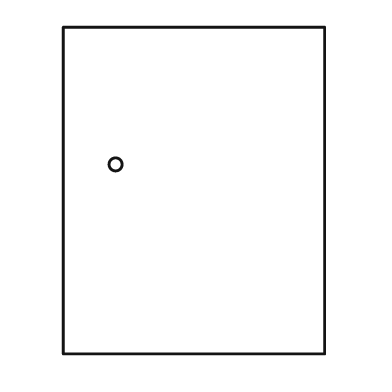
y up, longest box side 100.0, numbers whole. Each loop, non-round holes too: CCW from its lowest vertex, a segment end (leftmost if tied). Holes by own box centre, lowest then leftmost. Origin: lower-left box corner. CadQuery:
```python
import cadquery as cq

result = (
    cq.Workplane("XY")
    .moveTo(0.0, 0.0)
    .lineTo(80.0, 0.0)
    .lineTo(80.0, 100.0)
    .lineTo(0.0, 100.0)
    .close()
    .moveTo(16.0, 58.0)
    .circle(2.0)
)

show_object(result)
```